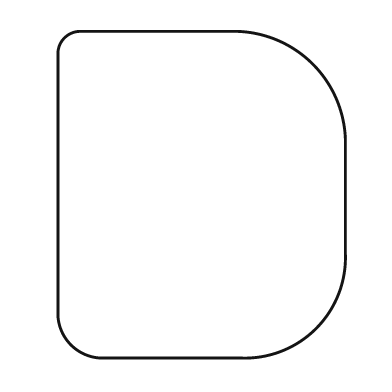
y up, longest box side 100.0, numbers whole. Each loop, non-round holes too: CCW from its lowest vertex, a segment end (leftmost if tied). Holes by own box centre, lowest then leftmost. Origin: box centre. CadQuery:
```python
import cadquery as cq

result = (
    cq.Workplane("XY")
    .moveTo(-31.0, -50.0)
    .lineTo(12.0, -50.0)
    .threePointArc((35.0, -41.0), (44.0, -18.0))
    .lineTo(44.0, 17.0)
    .threePointArc((34.0, 40.0), (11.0, 50.0))
    .lineTo(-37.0, 50.0)
    .threePointArc((-42.0, 48.0), (-44.0, 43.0))
    .lineTo(-44.0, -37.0)
    .threePointArc((-40.0, -46.0), (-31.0, -50.0))
    .close()
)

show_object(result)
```